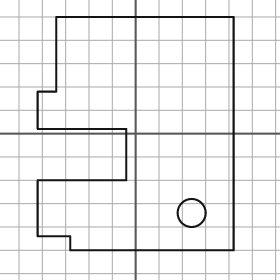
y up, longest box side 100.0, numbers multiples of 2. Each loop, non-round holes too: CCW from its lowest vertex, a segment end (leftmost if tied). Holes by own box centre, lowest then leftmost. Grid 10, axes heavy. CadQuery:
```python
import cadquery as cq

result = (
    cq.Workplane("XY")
    .moveTo(-28.0, -50.0)
    .lineTo(42.0, -50.0)
    .lineTo(42.0, 50.0)
    .lineTo(-34.0, 50.0)
    .lineTo(-34.0, 18.0)
    .lineTo(-42.0, 18.0)
    .lineTo(-42.0, 2.0)
    .lineTo(-4.0, 2.0)
    .lineTo(-4.0, -20.0)
    .lineTo(-42.0, -20.0)
    .lineTo(-42.0, -44.0)
    .lineTo(-28.0, -44.0)
    .close()
    .moveTo(24.0, -34.0)
    .circle(6.0)
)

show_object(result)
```